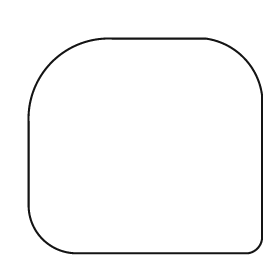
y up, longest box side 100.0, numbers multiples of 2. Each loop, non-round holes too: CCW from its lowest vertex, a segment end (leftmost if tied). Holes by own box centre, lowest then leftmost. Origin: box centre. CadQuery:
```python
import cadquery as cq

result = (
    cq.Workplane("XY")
    .moveTo(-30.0, -46.0)
    .lineTo(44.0, -46.0)
    .threePointArc((48.0, -44.0), (50.0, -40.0))
    .lineTo(50.0, 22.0)
    .threePointArc((42.0, 38.0), (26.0, 46.0))
    .lineTo(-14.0, 46.0)
    .threePointArc((-40.0, 36.0), (-50.0, 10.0))
    .lineTo(-50.0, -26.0)
    .threePointArc((-44.0, -40.0), (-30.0, -46.0))
    .close()
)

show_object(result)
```